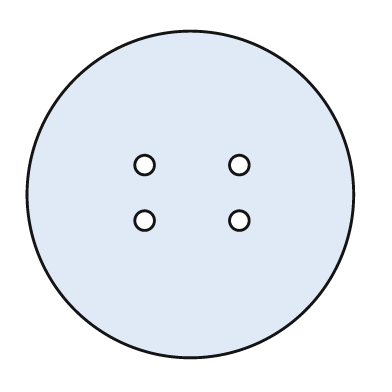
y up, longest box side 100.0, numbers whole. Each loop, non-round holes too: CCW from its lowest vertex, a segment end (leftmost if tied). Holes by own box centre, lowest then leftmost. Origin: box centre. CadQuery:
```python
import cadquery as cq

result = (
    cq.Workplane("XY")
    .moveTo(0.0, 0.0)
    .circle(50.0)
    .moveTo(-14.0, -8.0)
    .circle(3.0)
    .moveTo(15.0, -8.0)
    .circle(3.0)
    .moveTo(-14.0, 9.0)
    .circle(3.0)
    .moveTo(15.0, 9.0)
    .circle(3.0)
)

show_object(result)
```